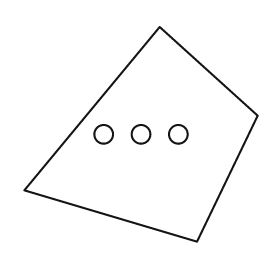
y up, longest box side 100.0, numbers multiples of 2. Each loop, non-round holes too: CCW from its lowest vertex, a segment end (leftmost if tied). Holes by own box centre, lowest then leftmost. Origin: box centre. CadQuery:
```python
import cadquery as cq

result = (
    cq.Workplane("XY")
    .moveTo(24.0, -46.0)
    .lineTo(50.0, 8.0)
    .lineTo(8.0, 46.0)
    .lineTo(-50.0, -24.0)
    .close()
    .moveTo(-16.0, 0.0)
    .circle(4.0)
    .moveTo(0.0, 0.0)
    .circle(4.0)
    .moveTo(16.0, 0.0)
    .circle(4.0)
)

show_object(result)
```